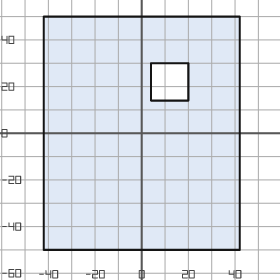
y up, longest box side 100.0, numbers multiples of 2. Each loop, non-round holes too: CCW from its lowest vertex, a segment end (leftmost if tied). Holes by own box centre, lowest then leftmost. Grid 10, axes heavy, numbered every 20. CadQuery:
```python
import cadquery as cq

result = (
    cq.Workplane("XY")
    .moveTo(-42.0, -50.0)
    .lineTo(42.0, -50.0)
    .lineTo(42.0, 50.0)
    .lineTo(-42.0, 50.0)
    .close()
    .moveTo(4.0, 14.0)
    .lineTo(20.0, 14.0)
    .lineTo(20.0, 30.0)
    .lineTo(4.0, 30.0)
    .close()
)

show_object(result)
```